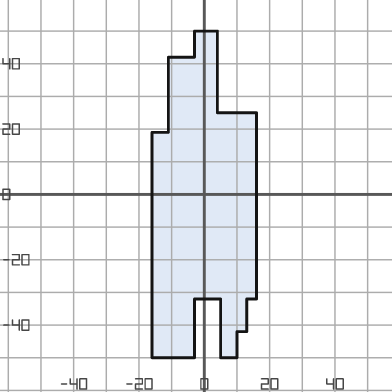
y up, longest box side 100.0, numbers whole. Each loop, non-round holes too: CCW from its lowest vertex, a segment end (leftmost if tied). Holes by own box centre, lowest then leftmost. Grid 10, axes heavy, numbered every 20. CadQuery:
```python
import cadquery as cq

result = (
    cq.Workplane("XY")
    .moveTo(-16.0, -50.0)
    .lineTo(-3.0, -50.0)
    .lineTo(-3.0, -32.0)
    .lineTo(5.0, -32.0)
    .lineTo(5.0, -50.0)
    .lineTo(10.0, -50.0)
    .lineTo(10.0, -42.0)
    .lineTo(13.0, -42.0)
    .lineTo(13.0, -32.0)
    .lineTo(16.0, -32.0)
    .lineTo(16.0, 25.0)
    .lineTo(4.0, 25.0)
    .lineTo(4.0, 50.0)
    .lineTo(-3.0, 50.0)
    .lineTo(-3.0, 42.0)
    .lineTo(-11.0, 42.0)
    .lineTo(-11.0, 19.0)
    .lineTo(-16.0, 19.0)
    .close()
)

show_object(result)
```